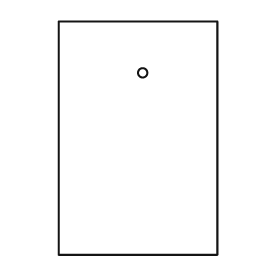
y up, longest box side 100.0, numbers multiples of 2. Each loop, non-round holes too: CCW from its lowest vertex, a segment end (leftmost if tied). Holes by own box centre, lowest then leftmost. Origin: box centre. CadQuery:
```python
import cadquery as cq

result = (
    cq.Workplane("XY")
    .moveTo(-34.0, -50.0)
    .lineTo(34.0, -50.0)
    .lineTo(34.0, 50.0)
    .lineTo(-34.0, 50.0)
    .close()
    .moveTo(2.0, 28.0)
    .circle(2.0)
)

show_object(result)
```